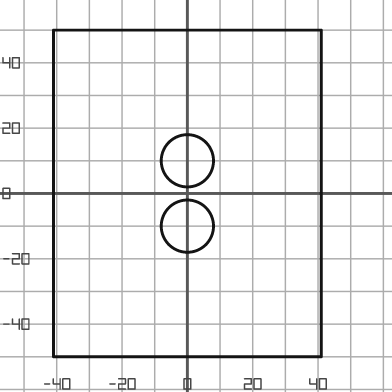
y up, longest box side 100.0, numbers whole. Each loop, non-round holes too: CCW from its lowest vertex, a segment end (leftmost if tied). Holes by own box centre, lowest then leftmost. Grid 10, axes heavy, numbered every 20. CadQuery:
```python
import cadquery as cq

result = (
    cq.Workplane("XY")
    .moveTo(-41.0, -50.0)
    .lineTo(41.0, -50.0)
    .lineTo(41.0, 50.0)
    .lineTo(-41.0, 50.0)
    .close()
    .moveTo(0.0, -10.0)
    .circle(8.0)
    .moveTo(0.0, 10.0)
    .circle(8.0)
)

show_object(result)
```